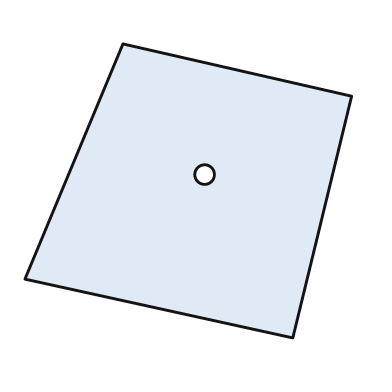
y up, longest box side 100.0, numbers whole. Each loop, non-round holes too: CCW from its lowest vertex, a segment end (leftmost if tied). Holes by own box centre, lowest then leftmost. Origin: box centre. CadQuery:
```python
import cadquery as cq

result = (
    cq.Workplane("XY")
    .moveTo(32.0, -45.0)
    .lineTo(50.0, 29.0)
    .lineTo(-20.0, 45.0)
    .lineTo(-50.0, -27.0)
    .close()
    .moveTo(5.0, 5.0)
    .circle(3.0)
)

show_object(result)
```